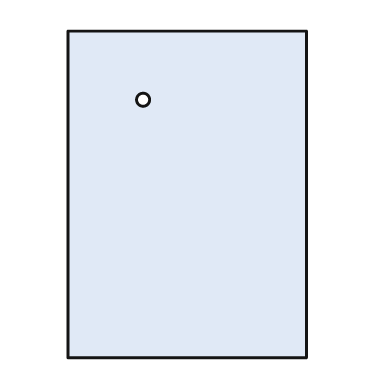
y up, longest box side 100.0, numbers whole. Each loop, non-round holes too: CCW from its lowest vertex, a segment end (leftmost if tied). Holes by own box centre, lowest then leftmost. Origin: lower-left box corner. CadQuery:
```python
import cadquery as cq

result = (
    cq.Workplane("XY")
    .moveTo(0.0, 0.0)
    .lineTo(73.0, 0.0)
    .lineTo(73.0, 100.0)
    .lineTo(0.0, 100.0)
    .close()
    .moveTo(23.0, 79.0)
    .circle(2.0)
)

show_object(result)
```